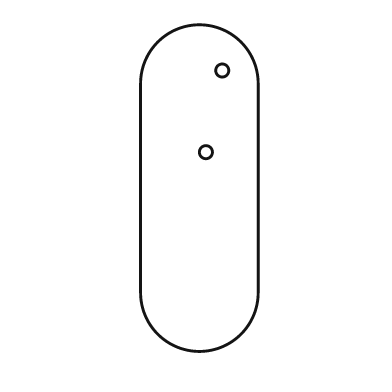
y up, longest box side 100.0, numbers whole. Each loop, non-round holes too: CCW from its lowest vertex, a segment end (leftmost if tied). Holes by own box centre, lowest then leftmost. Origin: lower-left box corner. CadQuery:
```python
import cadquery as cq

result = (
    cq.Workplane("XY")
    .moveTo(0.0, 18.0)
    .threePointArc((18.0, 0.0), (36.0, 18.0))
    .lineTo(36.0, 82.0)
    .threePointArc((18.0, 100.0), (0.0, 82.0))
    .close()
    .moveTo(20.0, 61.0)
    .circle(2.0)
    .moveTo(25.0, 86.0)
    .circle(2.0)
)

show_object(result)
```